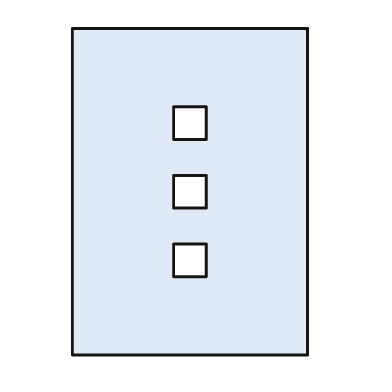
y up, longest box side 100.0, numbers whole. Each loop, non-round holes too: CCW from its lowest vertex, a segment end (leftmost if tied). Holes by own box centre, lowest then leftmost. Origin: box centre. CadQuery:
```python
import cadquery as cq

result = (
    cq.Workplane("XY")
    .moveTo(-36.0, -50.0)
    .lineTo(36.0, -50.0)
    .lineTo(36.0, 50.0)
    .lineTo(-36.0, 50.0)
    .close()
    .moveTo(-5.0, -26.0)
    .lineTo(5.0, -26.0)
    .lineTo(5.0, -16.0)
    .lineTo(-5.0, -16.0)
    .close()
    .moveTo(-5.0, -5.0)
    .lineTo(5.0, -5.0)
    .lineTo(5.0, 5.0)
    .lineTo(-5.0, 5.0)
    .close()
    .moveTo(-5.0, 16.0)
    .lineTo(5.0, 16.0)
    .lineTo(5.0, 26.0)
    .lineTo(-5.0, 26.0)
    .close()
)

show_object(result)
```